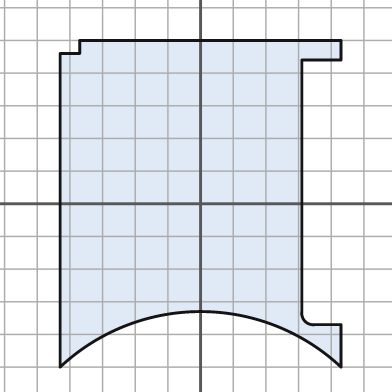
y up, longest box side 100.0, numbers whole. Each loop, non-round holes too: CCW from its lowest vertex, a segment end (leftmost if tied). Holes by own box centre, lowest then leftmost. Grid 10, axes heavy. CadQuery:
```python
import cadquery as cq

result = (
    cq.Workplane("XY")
    .moveTo(-43.0, -50.0)
    .threePointArc((0.0, -33.0), (43.0, -50.0))
    .lineTo(43.0, -37.0)
    .lineTo(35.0, -37.0)
    .threePointArc((32.0, -36.0), (31.0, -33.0))
    .lineTo(31.0, 44.0)
    .lineTo(43.0, 44.0)
    .lineTo(43.0, 50.0)
    .lineTo(-37.0, 50.0)
    .lineTo(-37.0, 46.0)
    .lineTo(-43.0, 46.0)
    .close()
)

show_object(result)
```